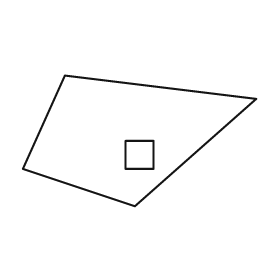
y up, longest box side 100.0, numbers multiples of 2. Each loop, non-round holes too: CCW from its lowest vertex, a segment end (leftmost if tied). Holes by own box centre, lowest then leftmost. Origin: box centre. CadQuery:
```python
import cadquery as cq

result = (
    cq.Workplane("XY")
    .moveTo(-2.0, -28.0)
    .lineTo(50.0, 18.0)
    .lineTo(-32.0, 28.0)
    .lineTo(-50.0, -12.0)
    .close()
    .moveTo(-6.0, -12.0)
    .lineTo(6.0, -12.0)
    .lineTo(6.0, 0.0)
    .lineTo(-6.0, 0.0)
    .close()
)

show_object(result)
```